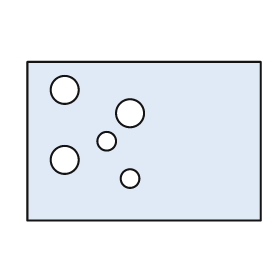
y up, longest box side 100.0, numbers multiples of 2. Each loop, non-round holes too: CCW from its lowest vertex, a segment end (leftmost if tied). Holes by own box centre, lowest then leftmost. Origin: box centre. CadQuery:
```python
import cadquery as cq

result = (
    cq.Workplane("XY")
    .moveTo(-50.0, -34.0)
    .lineTo(50.0, -34.0)
    .lineTo(50.0, 34.0)
    .lineTo(-50.0, 34.0)
    .close()
    .moveTo(-6.0, -16.0)
    .circle(4.0)
    .moveTo(-34.0, -8.0)
    .circle(6.0)
    .moveTo(-16.0, 0.0)
    .circle(4.0)
    .moveTo(-6.0, 12.0)
    .circle(6.0)
    .moveTo(-34.0, 22.0)
    .circle(6.0)
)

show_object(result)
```